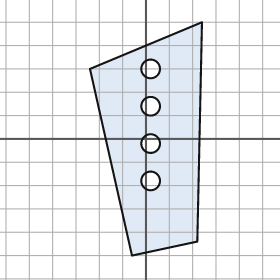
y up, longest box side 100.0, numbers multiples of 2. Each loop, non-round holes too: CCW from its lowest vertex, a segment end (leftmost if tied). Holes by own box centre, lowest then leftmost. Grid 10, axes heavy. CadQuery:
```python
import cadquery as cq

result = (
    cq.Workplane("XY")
    .moveTo(-6.0, -50.0)
    .lineTo(22.0, -44.0)
    .lineTo(24.0, 50.0)
    .lineTo(-24.0, 30.0)
    .close()
    .moveTo(2.0, -18.0)
    .circle(4.0)
    .moveTo(2.0, -2.0)
    .circle(4.0)
    .moveTo(2.0, 14.0)
    .circle(4.0)
    .moveTo(2.0, 30.0)
    .circle(4.0)
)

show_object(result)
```